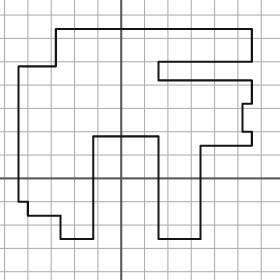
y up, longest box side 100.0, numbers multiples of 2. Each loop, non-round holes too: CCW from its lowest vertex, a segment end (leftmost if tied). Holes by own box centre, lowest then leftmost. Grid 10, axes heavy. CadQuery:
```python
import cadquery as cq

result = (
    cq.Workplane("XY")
    .moveTo(-26.0, -26.0)
    .lineTo(-12.0, -26.0)
    .lineTo(-12.0, 18.0)
    .lineTo(16.0, 18.0)
    .lineTo(16.0, -26.0)
    .lineTo(34.0, -26.0)
    .lineTo(34.0, 14.0)
    .lineTo(56.0, 14.0)
    .lineTo(56.0, 20.0)
    .lineTo(52.0, 20.0)
    .lineTo(52.0, 32.0)
    .lineTo(56.0, 32.0)
    .lineTo(56.0, 42.0)
    .lineTo(16.0, 42.0)
    .lineTo(16.0, 50.0)
    .lineTo(56.0, 50.0)
    .lineTo(56.0, 64.0)
    .lineTo(-28.0, 64.0)
    .lineTo(-28.0, 48.0)
    .lineTo(-44.0, 48.0)
    .lineTo(-44.0, -10.0)
    .lineTo(-40.0, -10.0)
    .lineTo(-40.0, -16.0)
    .lineTo(-26.0, -16.0)
    .close()
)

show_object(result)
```